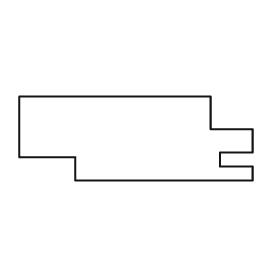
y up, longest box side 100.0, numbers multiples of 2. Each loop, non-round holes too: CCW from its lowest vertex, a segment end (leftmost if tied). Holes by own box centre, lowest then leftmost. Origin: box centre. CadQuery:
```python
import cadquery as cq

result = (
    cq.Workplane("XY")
    .moveTo(-26.0, -18.0)
    .lineTo(50.0, -18.0)
    .lineTo(50.0, -12.0)
    .lineTo(36.0, -12.0)
    .lineTo(36.0, -6.0)
    .lineTo(50.0, -6.0)
    .lineTo(50.0, 4.0)
    .lineTo(32.0, 4.0)
    .lineTo(32.0, 18.0)
    .lineTo(-50.0, 18.0)
    .lineTo(-50.0, -8.0)
    .lineTo(-26.0, -8.0)
    .close()
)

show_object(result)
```